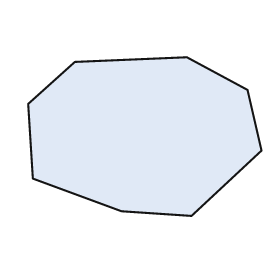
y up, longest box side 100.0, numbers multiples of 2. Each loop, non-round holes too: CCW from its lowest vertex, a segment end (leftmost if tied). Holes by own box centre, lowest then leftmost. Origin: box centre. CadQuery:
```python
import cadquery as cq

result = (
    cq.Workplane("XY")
    .moveTo(20.0, -34.0)
    .lineTo(50.0, -6.0)
    .lineTo(44.0, 20.0)
    .lineTo(18.0, 34.0)
    .lineTo(-30.0, 32.0)
    .lineTo(-50.0, 14.0)
    .lineTo(-48.0, -18.0)
    .lineTo(-10.0, -32.0)
    .close()
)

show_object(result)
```